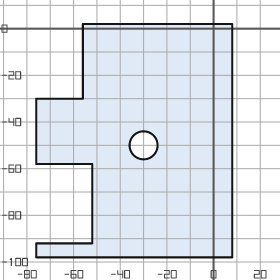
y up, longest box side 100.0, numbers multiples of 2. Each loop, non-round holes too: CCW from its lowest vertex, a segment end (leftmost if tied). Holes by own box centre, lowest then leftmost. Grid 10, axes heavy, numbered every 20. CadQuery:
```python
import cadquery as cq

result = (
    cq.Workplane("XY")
    .moveTo(-76.0, -98.0)
    .lineTo(8.0, -98.0)
    .lineTo(8.0, 2.0)
    .lineTo(-56.0, 2.0)
    .lineTo(-56.0, -30.0)
    .lineTo(-76.0, -30.0)
    .lineTo(-76.0, -58.0)
    .lineTo(-52.0, -58.0)
    .lineTo(-52.0, -92.0)
    .lineTo(-76.0, -92.0)
    .close()
    .moveTo(-30.0, -50.0)
    .circle(6.0)
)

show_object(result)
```